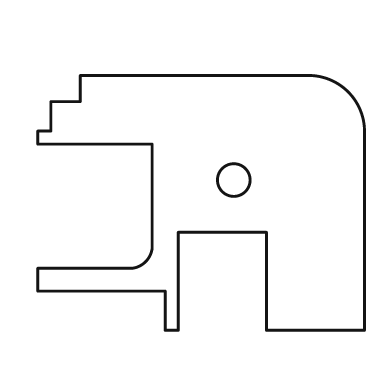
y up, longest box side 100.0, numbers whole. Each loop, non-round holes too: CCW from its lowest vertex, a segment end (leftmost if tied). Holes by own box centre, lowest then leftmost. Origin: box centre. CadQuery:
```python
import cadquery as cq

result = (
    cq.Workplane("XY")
    .moveTo(-11.0, -39.0)
    .lineTo(-7.0, -39.0)
    .lineTo(-7.0, -9.0)
    .lineTo(20.0, -9.0)
    .lineTo(20.0, -39.0)
    .lineTo(50.0, -39.0)
    .lineTo(50.0, 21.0)
    .threePointArc((45.0, 34.0), (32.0, 39.0))
    .lineTo(-37.0, 39.0)
    .lineTo(-37.0, 31.0)
    .lineTo(-46.0, 31.0)
    .lineTo(-46.0, 22.0)
    .lineTo(-50.0, 22.0)
    .lineTo(-50.0, 18.0)
    .lineTo(-15.0, 18.0)
    .lineTo(-15.0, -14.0)
    .threePointArc((-17.0, -18.0), (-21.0, -20.0))
    .lineTo(-50.0, -20.0)
    .lineTo(-50.0, -27.0)
    .lineTo(-11.0, -27.0)
    .close()
    .moveTo(10.0, 7.0)
    .circle(5.0)
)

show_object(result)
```